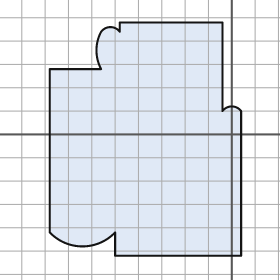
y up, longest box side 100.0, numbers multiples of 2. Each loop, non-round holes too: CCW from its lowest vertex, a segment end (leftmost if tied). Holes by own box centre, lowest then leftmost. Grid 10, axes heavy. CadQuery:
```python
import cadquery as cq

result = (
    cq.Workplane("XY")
    .moveTo(-50.0, -52.0)
    .lineTo(4.0, -52.0)
    .lineTo(4.0, 10.0)
    .threePointArc((0.0, 12.0), (-4.0, 10.0))
    .lineTo(-4.0, 48.0)
    .lineTo(-48.0, 48.0)
    .lineTo(-48.0, 44.0)
    .threePointArc((-52.0, 46.0), (-56.0, 44.0))
    .threePointArc((-58.0, 36.0), (-56.0, 28.0))
    .lineTo(-78.0, 28.0)
    .lineTo(-78.0, -42.0)
    .threePointArc((-64.0, -48.0), (-50.0, -42.0))
    .close()
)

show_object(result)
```